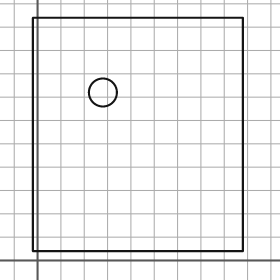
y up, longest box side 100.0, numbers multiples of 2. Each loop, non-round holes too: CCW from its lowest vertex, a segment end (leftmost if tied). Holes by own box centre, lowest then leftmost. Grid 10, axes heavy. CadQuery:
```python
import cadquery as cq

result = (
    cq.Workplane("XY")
    .moveTo(-2.0, 4.0)
    .lineTo(88.0, 4.0)
    .lineTo(88.0, 104.0)
    .lineTo(-2.0, 104.0)
    .close()
    .moveTo(28.0, 72.0)
    .circle(6.0)
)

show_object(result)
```